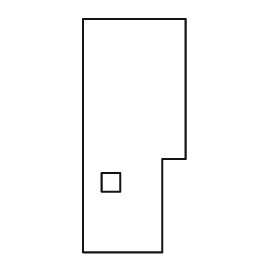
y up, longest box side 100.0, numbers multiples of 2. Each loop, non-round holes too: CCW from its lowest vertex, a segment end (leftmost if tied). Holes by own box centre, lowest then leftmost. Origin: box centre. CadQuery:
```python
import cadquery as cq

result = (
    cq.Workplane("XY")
    .moveTo(-22.0, -50.0)
    .lineTo(12.0, -50.0)
    .lineTo(12.0, -10.0)
    .lineTo(22.0, -10.0)
    .lineTo(22.0, 50.0)
    .lineTo(-22.0, 50.0)
    .close()
    .moveTo(-14.0, -24.0)
    .lineTo(-6.0, -24.0)
    .lineTo(-6.0, -16.0)
    .lineTo(-14.0, -16.0)
    .close()
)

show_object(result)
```